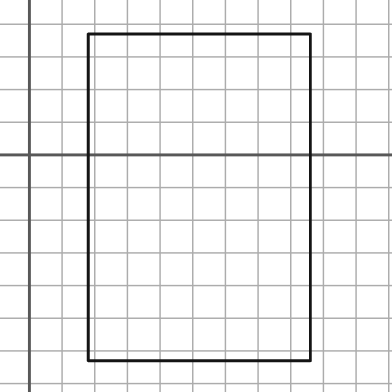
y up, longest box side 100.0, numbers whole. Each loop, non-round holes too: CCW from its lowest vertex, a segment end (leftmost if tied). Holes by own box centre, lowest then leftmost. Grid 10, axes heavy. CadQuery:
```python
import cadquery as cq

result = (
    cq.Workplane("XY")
    .moveTo(18.0, -63.0)
    .lineTo(86.0, -63.0)
    .lineTo(86.0, 37.0)
    .lineTo(18.0, 37.0)
    .close()
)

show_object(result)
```